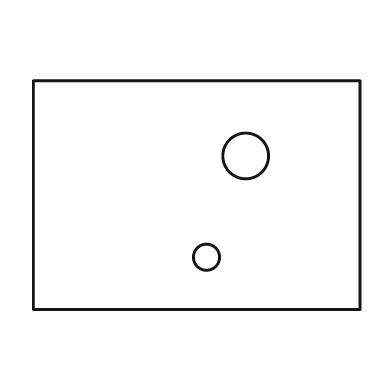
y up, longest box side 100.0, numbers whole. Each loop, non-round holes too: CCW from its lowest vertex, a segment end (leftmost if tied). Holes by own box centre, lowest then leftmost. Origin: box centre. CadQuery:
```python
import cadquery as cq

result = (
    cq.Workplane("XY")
    .moveTo(-50.0, -35.0)
    .lineTo(50.0, -35.0)
    .lineTo(50.0, 35.0)
    .lineTo(-50.0, 35.0)
    .close()
    .moveTo(3.0, -19.0)
    .circle(4.0)
    .moveTo(15.0, 12.0)
    .circle(7.0)
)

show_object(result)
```